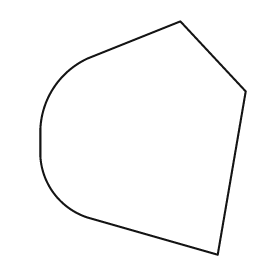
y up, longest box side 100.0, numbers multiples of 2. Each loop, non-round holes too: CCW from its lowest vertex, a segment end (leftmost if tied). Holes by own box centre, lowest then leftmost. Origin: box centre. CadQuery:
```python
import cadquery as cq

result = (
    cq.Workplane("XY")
    .moveTo(32.0, -50.0)
    .lineTo(44.0, 20.0)
    .lineTo(16.0, 50.0)
    .lineTo(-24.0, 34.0)
    .threePointArc((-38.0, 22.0), (-44.0, 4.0))
    .lineTo(-44.0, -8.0)
    .threePointArc((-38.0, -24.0), (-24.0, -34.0))
    .close()
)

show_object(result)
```